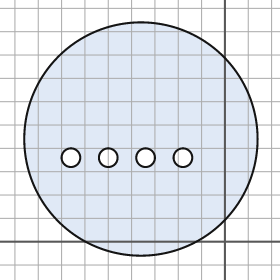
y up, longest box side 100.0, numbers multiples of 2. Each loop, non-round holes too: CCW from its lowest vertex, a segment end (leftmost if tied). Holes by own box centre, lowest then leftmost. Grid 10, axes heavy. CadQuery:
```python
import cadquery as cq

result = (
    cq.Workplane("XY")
    .moveTo(-36.0, 44.0)
    .circle(50.0)
    .moveTo(-66.0, 36.0)
    .circle(4.0)
    .moveTo(-50.0, 36.0)
    .circle(4.0)
    .moveTo(-34.0, 36.0)
    .circle(4.0)
    .moveTo(-18.0, 36.0)
    .circle(4.0)
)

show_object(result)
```